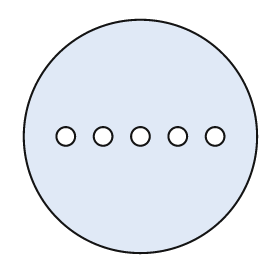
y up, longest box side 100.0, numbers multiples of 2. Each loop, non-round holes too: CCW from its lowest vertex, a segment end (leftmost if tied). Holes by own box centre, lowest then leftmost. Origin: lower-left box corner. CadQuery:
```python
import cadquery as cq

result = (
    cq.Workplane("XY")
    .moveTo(50.0, 50.0)
    .circle(50.0)
    .moveTo(18.0, 50.0)
    .circle(4.0)
    .moveTo(34.0, 50.0)
    .circle(4.0)
    .moveTo(50.0, 50.0)
    .circle(4.0)
    .moveTo(66.0, 50.0)
    .circle(4.0)
    .moveTo(82.0, 50.0)
    .circle(4.0)
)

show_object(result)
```